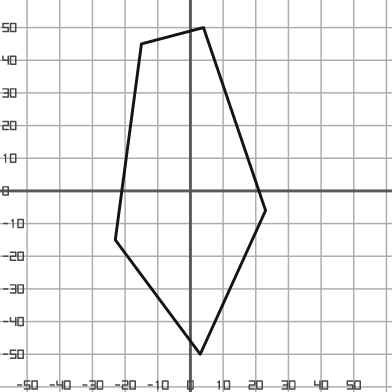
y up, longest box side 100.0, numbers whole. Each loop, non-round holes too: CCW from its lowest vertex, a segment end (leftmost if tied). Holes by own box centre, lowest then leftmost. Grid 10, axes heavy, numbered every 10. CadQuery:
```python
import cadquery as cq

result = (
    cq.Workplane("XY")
    .moveTo(3.0, -50.0)
    .lineTo(23.0, -6.0)
    .lineTo(4.0, 50.0)
    .lineTo(-15.0, 45.0)
    .lineTo(-23.0, -15.0)
    .close()
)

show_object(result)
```